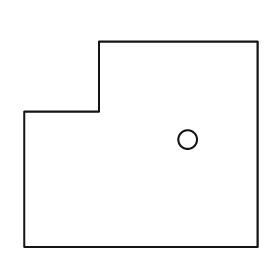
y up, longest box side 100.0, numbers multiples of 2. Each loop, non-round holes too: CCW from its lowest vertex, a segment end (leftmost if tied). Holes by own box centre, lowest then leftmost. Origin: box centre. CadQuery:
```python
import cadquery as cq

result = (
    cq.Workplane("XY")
    .moveTo(-50.0, -44.0)
    .lineTo(50.0, -44.0)
    .lineTo(50.0, 44.0)
    .lineTo(-18.0, 44.0)
    .lineTo(-18.0, 14.0)
    .lineTo(-50.0, 14.0)
    .close()
    .moveTo(20.0, 2.0)
    .circle(4.0)
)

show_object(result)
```